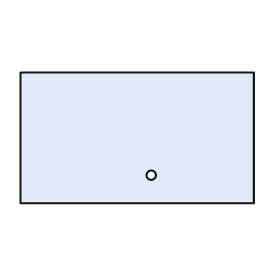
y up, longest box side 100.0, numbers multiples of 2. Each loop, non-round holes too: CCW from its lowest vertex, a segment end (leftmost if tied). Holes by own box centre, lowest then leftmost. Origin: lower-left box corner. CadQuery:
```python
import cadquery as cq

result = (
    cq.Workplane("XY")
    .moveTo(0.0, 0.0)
    .lineTo(100.0, 0.0)
    .lineTo(100.0, 56.0)
    .lineTo(0.0, 56.0)
    .close()
    .moveTo(56.0, 12.0)
    .circle(2.0)
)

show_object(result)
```